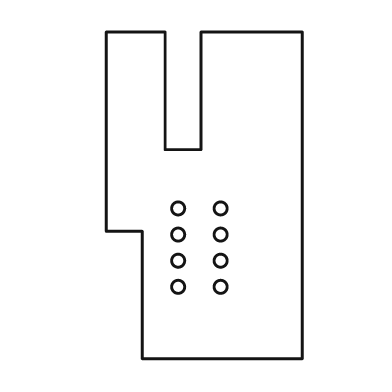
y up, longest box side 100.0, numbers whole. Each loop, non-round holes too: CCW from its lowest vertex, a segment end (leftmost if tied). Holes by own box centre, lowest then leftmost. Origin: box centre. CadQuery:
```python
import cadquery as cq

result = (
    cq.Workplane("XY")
    .moveTo(-19.0, -50.0)
    .lineTo(30.0, -50.0)
    .lineTo(30.0, 50.0)
    .lineTo(-1.0, 50.0)
    .lineTo(-1.0, 14.0)
    .lineTo(-12.0, 14.0)
    .lineTo(-12.0, 50.0)
    .lineTo(-30.0, 50.0)
    .lineTo(-30.0, -11.0)
    .lineTo(-19.0, -11.0)
    .close()
    .moveTo(-8.0, -28.0)
    .circle(2.0)
    .moveTo(5.0, -28.0)
    .circle(2.0)
    .moveTo(-8.0, -20.0)
    .circle(2.0)
    .moveTo(5.0, -20.0)
    .circle(2.0)
    .moveTo(-8.0, -12.0)
    .circle(2.0)
    .moveTo(5.0, -12.0)
    .circle(2.0)
    .moveTo(-8.0, -4.0)
    .circle(2.0)
    .moveTo(5.0, -4.0)
    .circle(2.0)
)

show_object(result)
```